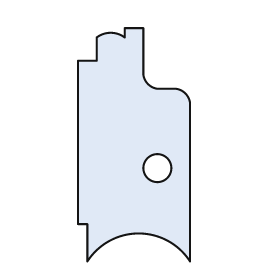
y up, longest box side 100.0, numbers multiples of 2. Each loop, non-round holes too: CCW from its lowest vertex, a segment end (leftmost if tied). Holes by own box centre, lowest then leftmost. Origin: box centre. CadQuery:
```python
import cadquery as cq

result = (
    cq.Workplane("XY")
    .moveTo(-20.0, -50.0)
    .threePointArc((2.0, -38.0), (24.0, -50.0))
    .lineTo(24.0, 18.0)
    .threePointArc((22.0, 22.0), (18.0, 24.0))
    .lineTo(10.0, 24.0)
    .threePointArc((6.0, 26.0), (4.0, 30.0))
    .lineTo(4.0, 50.0)
    .lineTo(-4.0, 50.0)
    .lineTo(-4.0, 46.0)
    .threePointArc((-10.0, 48.0), (-16.0, 46.0))
    .lineTo(-16.0, 36.0)
    .lineTo(-24.0, 36.0)
    .lineTo(-24.0, -34.0)
    .lineTo(-20.0, -34.0)
    .close()
    .moveTo(10.0, -10.0)
    .circle(6.0)
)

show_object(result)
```